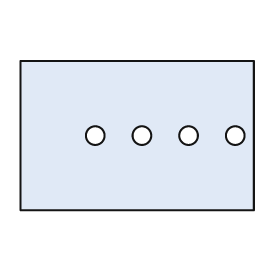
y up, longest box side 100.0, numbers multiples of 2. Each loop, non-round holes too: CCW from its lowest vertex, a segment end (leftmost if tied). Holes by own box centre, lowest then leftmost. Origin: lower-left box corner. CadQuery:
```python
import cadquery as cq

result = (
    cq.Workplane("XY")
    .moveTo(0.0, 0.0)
    .lineTo(100.0, 0.0)
    .lineTo(100.0, 64.0)
    .lineTo(0.0, 64.0)
    .close()
    .moveTo(32.0, 32.0)
    .circle(4.0)
    .moveTo(52.0, 32.0)
    .circle(4.0)
    .moveTo(72.0, 32.0)
    .circle(4.0)
    .moveTo(92.0, 32.0)
    .circle(4.0)
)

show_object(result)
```